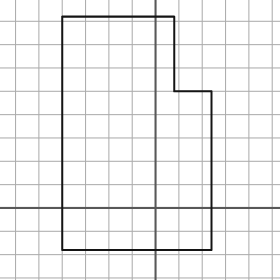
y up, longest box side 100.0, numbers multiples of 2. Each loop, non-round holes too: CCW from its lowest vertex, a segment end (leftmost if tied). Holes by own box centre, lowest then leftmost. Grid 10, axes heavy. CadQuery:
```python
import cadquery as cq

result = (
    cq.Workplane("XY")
    .moveTo(-40.0, -18.0)
    .lineTo(24.0, -18.0)
    .lineTo(24.0, 50.0)
    .lineTo(8.0, 50.0)
    .lineTo(8.0, 82.0)
    .lineTo(-40.0, 82.0)
    .close()
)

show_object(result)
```